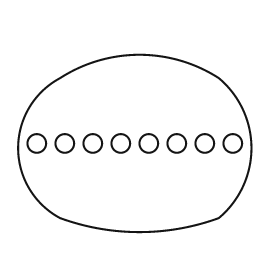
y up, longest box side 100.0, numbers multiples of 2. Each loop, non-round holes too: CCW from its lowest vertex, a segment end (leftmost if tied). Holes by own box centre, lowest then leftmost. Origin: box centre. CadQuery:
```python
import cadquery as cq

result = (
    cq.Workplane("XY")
    .moveTo(-32.0, -32.0)
    .threePointArc((2.0, -38.0), (36.0, -32.0))
    .threePointArc((50.0, -2.0), (36.0, 28.0))
    .threePointArc((2.0, 38.0), (-32.0, 28.0))
    .threePointArc((-50.0, -2.0), (-32.0, -32.0))
    .close()
    .moveTo(-42.0, 0.0)
    .circle(4.0)
    .moveTo(-30.0, 0.0)
    .circle(4.0)
    .moveTo(-18.0, 0.0)
    .circle(4.0)
    .moveTo(-6.0, 0.0)
    .circle(4.0)
    .moveTo(6.0, 0.0)
    .circle(4.0)
    .moveTo(18.0, 0.0)
    .circle(4.0)
    .moveTo(30.0, 0.0)
    .circle(4.0)
    .moveTo(42.0, 0.0)
    .circle(4.0)
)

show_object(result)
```